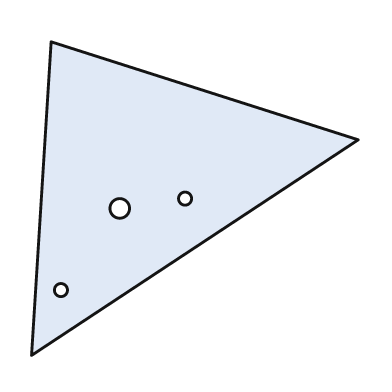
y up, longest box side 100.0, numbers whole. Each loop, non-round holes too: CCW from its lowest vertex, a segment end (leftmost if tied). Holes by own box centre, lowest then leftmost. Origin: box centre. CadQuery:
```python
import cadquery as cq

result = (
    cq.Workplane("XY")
    .moveTo(-50.0, -48.0)
    .lineTo(50.0, 18.0)
    .lineTo(-44.0, 48.0)
    .close()
    .moveTo(-41.0, -28.0)
    .circle(2.0)
    .moveTo(-23.0, -3.0)
    .circle(3.0)
    .moveTo(-3.0, 0.0)
    .circle(2.0)
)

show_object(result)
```